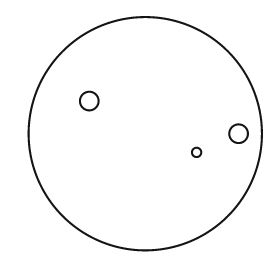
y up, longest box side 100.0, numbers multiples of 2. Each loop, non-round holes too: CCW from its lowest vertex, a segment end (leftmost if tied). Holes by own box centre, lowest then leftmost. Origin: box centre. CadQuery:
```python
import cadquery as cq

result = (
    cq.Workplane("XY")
    .moveTo(0.0, 0.0)
    .circle(50.0)
    .moveTo(22.0, -8.0)
    .circle(2.0)
    .moveTo(40.0, 0.0)
    .circle(4.0)
    .moveTo(-24.0, 14.0)
    .circle(4.0)
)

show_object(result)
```